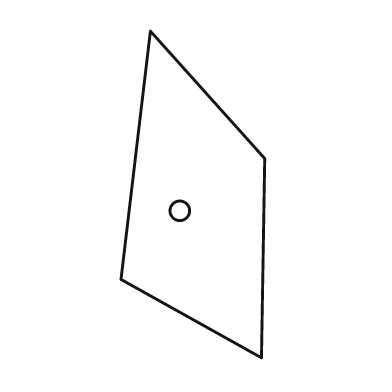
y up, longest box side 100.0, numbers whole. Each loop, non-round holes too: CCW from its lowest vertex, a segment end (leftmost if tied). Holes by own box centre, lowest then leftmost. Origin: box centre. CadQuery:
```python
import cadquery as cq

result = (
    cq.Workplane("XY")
    .moveTo(21.0, -50.0)
    .lineTo(22.0, 11.0)
    .lineTo(-13.0, 50.0)
    .lineTo(-22.0, -26.0)
    .close()
    .moveTo(-4.0, -5.0)
    .circle(3.0)
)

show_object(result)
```